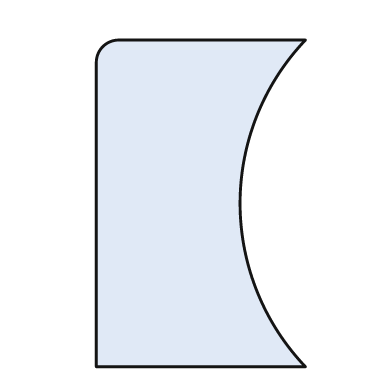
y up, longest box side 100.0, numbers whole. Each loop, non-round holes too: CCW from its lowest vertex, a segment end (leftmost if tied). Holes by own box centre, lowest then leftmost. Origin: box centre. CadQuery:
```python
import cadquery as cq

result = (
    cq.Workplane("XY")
    .moveTo(-32.0, -50.0)
    .lineTo(32.0, -50.0)
    .threePointArc((12.0, 0.0), (32.0, 50.0))
    .lineTo(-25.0, 50.0)
    .threePointArc((-30.0, 48.0), (-32.0, 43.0))
    .close()
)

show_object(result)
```